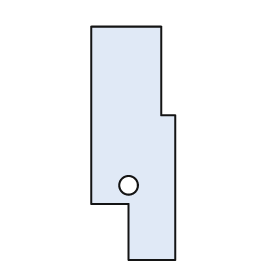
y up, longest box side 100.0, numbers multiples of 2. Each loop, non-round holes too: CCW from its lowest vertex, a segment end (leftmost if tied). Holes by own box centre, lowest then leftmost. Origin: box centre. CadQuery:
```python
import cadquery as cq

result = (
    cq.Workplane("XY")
    .moveTo(-2.0, -50.0)
    .lineTo(18.0, -50.0)
    .lineTo(18.0, 12.0)
    .lineTo(12.0, 12.0)
    .lineTo(12.0, 50.0)
    .lineTo(-18.0, 50.0)
    .lineTo(-18.0, -26.0)
    .lineTo(-2.0, -26.0)
    .close()
    .moveTo(-2.0, -18.0)
    .circle(4.0)
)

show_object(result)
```